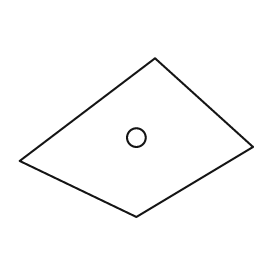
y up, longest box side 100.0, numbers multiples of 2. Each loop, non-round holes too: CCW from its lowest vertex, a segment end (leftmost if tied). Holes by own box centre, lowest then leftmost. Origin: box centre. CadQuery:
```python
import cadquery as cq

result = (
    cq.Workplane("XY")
    .moveTo(0.0, -34.0)
    .lineTo(50.0, -4.0)
    .lineTo(8.0, 34.0)
    .lineTo(-50.0, -10.0)
    .close()
    .moveTo(0.0, 0.0)
    .circle(4.0)
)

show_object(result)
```